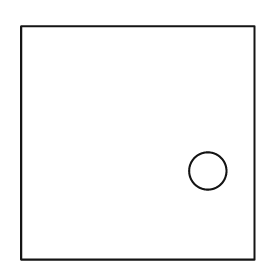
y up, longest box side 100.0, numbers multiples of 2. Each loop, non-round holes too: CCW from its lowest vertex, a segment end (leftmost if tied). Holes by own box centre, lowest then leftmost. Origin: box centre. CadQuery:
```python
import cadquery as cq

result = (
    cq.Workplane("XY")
    .moveTo(-50.0, -50.0)
    .lineTo(50.0, -50.0)
    .lineTo(50.0, 50.0)
    .lineTo(-50.0, 50.0)
    .close()
    .moveTo(30.0, -12.0)
    .circle(8.0)
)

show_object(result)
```